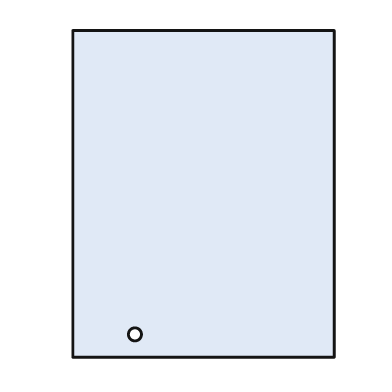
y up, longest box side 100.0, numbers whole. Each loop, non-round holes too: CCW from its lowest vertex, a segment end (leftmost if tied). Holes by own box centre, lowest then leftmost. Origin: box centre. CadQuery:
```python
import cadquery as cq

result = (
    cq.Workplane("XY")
    .moveTo(-40.0, -50.0)
    .lineTo(40.0, -50.0)
    .lineTo(40.0, 50.0)
    .lineTo(-40.0, 50.0)
    .close()
    .moveTo(-21.0, -43.0)
    .circle(2.0)
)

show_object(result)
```